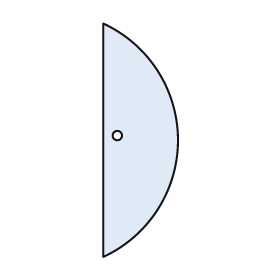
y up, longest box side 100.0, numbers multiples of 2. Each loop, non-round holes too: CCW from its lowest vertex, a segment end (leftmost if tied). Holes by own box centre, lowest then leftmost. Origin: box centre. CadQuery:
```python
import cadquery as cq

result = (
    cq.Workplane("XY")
    .moveTo(-16.0, -50.0)
    .threePointArc((16.0, 0.0), (-16.0, 50.0))
    .close()
    .moveTo(-10.0, 2.0)
    .circle(2.0)
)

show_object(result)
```